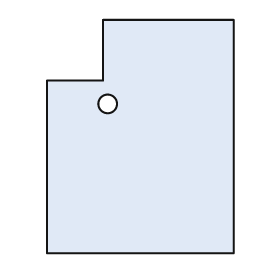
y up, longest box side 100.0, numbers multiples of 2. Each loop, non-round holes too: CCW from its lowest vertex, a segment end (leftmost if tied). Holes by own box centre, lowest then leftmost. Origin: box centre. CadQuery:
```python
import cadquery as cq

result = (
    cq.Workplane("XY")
    .moveTo(-40.0, -50.0)
    .lineTo(40.0, -50.0)
    .lineTo(40.0, 50.0)
    .lineTo(-16.0, 50.0)
    .lineTo(-16.0, 24.0)
    .lineTo(-40.0, 24.0)
    .close()
    .moveTo(-14.0, 14.0)
    .circle(4.0)
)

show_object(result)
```